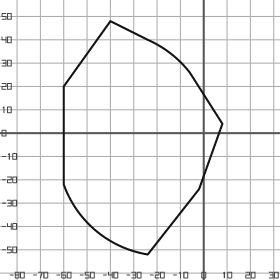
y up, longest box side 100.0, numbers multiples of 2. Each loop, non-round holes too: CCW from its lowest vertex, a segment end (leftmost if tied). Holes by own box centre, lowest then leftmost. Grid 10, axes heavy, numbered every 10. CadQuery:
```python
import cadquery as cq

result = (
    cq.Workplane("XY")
    .moveTo(-24.0, -52.0)
    .lineTo(-2.0, -24.0)
    .lineTo(8.0, 4.0)
    .lineTo(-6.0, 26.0)
    .threePointArc((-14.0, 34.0), (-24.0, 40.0))
    .lineTo(-40.0, 48.0)
    .lineTo(-60.0, 20.0)
    .lineTo(-60.0, -22.0)
    .threePointArc((-46.0, -42.0), (-24.0, -52.0))
    .close()
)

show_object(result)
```